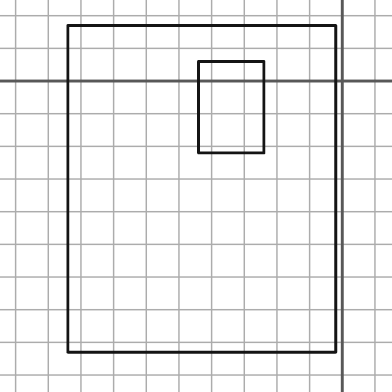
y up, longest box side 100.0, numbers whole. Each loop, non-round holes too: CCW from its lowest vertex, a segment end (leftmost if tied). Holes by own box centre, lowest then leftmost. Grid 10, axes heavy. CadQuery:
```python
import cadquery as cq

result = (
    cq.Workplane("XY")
    .moveTo(-84.0, -83.0)
    .lineTo(-2.0, -83.0)
    .lineTo(-2.0, 17.0)
    .lineTo(-84.0, 17.0)
    .close()
    .moveTo(-44.0, -22.0)
    .lineTo(-24.0, -22.0)
    .lineTo(-24.0, 6.0)
    .lineTo(-44.0, 6.0)
    .close()
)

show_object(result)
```